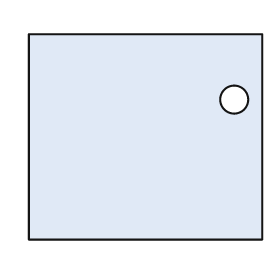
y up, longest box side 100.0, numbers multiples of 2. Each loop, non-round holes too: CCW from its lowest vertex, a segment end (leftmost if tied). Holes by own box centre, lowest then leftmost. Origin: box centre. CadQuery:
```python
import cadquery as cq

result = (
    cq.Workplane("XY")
    .moveTo(-50.0, -44.0)
    .lineTo(50.0, -44.0)
    .lineTo(50.0, 44.0)
    .lineTo(-50.0, 44.0)
    .close()
    .moveTo(38.0, 16.0)
    .circle(6.0)
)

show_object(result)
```